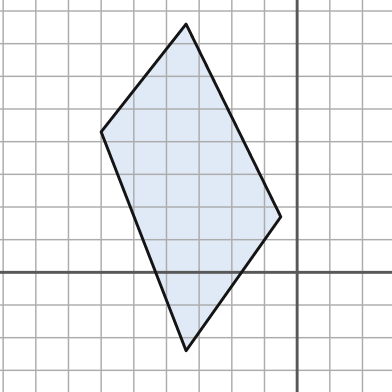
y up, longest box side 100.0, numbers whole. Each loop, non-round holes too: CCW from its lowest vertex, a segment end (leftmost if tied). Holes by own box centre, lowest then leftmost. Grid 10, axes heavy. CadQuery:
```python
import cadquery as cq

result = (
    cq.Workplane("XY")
    .moveTo(-34.0, -24.0)
    .lineTo(-5.0, 17.0)
    .lineTo(-34.0, 76.0)
    .lineTo(-60.0, 43.0)
    .close()
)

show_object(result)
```